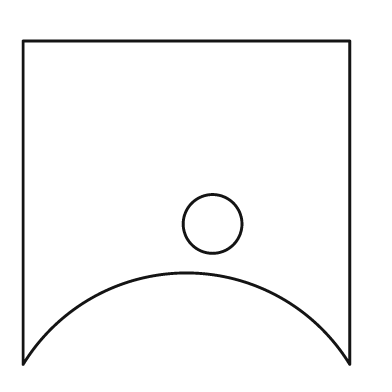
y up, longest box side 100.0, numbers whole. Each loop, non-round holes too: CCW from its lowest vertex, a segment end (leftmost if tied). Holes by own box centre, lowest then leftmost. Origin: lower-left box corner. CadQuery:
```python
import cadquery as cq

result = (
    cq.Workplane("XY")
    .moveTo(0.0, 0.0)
    .threePointArc((50.0, 28.0), (100.0, 0.0))
    .lineTo(100.0, 99.0)
    .lineTo(0.0, 99.0)
    .close()
    .moveTo(58.0, 43.0)
    .circle(9.0)
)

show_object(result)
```